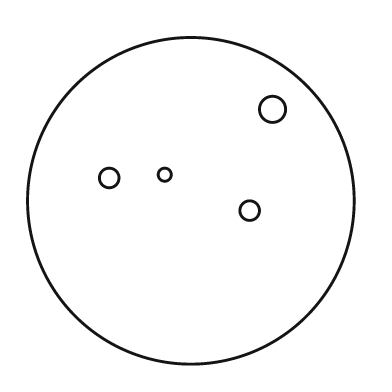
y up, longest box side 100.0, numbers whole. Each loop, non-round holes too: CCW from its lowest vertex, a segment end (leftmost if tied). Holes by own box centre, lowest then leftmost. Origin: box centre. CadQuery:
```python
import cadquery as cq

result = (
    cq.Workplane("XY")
    .moveTo(0.0, 0.0)
    .circle(50.0)
    .moveTo(18.0, -3.0)
    .circle(3.0)
    .moveTo(-25.0, 7.0)
    .circle(3.0)
    .moveTo(-8.0, 8.0)
    .circle(2.0)
    .moveTo(25.0, 28.0)
    .circle(4.0)
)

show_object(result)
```